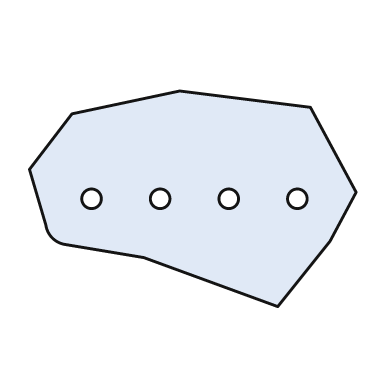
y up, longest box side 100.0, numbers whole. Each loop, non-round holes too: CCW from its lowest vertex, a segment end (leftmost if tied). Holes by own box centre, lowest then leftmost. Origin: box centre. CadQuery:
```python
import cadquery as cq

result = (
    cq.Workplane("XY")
    .moveTo(26.0, -33.0)
    .lineTo(42.0, -13.0)
    .lineTo(50.0, 2.0)
    .lineTo(36.0, 28.0)
    .lineTo(-4.0, 33.0)
    .lineTo(-37.0, 26.0)
    .lineTo(-50.0, 9.0)
    .lineTo(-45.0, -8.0)
    .threePointArc((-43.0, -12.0), (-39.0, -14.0))
    .lineTo(-15.0, -18.0)
    .close()
    .moveTo(-31.0, 0.0)
    .circle(3.0)
    .moveTo(-10.0, 0.0)
    .circle(3.0)
    .moveTo(11.0, 0.0)
    .circle(3.0)
    .moveTo(32.0, 0.0)
    .circle(3.0)
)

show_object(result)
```